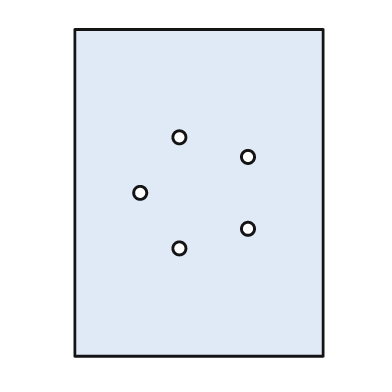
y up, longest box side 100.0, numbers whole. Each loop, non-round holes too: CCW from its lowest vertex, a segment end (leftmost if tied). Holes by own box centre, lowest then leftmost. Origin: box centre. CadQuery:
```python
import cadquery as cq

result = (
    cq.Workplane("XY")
    .moveTo(-38.0, -50.0)
    .lineTo(38.0, -50.0)
    .lineTo(38.0, 50.0)
    .lineTo(-38.0, 50.0)
    .close()
    .moveTo(-6.0, -17.0)
    .circle(2.0)
    .moveTo(15.0, -11.0)
    .circle(2.0)
    .moveTo(-18.0, 0.0)
    .circle(2.0)
    .moveTo(15.0, 11.0)
    .circle(2.0)
    .moveTo(-6.0, 17.0)
    .circle(2.0)
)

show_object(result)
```